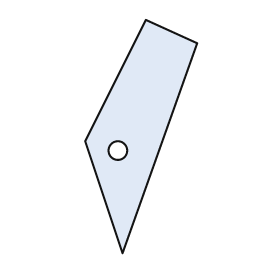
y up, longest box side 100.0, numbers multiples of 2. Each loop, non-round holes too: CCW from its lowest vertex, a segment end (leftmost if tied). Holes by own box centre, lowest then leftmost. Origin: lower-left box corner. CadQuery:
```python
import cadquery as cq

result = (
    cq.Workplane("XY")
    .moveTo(16.0, 0.0)
    .lineTo(48.0, 90.0)
    .lineTo(26.0, 100.0)
    .lineTo(0.0, 48.0)
    .close()
    .moveTo(14.0, 44.0)
    .circle(4.0)
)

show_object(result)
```